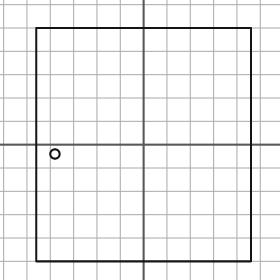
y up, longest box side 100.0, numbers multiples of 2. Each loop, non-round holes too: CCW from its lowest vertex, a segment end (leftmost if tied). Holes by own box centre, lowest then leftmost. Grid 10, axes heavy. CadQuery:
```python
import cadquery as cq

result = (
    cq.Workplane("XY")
    .moveTo(-46.0, -50.0)
    .lineTo(46.0, -50.0)
    .lineTo(46.0, 50.0)
    .lineTo(-46.0, 50.0)
    .close()
    .moveTo(-38.0, -4.0)
    .circle(2.0)
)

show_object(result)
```